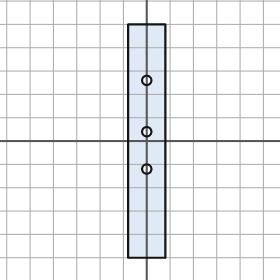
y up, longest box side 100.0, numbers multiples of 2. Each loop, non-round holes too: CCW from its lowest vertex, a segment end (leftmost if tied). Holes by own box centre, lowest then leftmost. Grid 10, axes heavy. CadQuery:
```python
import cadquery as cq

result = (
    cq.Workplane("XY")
    .moveTo(-8.0, -50.0)
    .lineTo(8.0, -50.0)
    .lineTo(8.0, 50.0)
    .lineTo(-8.0, 50.0)
    .close()
    .moveTo(0.0, -12.0)
    .circle(2.0)
    .moveTo(0.0, 4.0)
    .circle(2.0)
    .moveTo(0.0, 26.0)
    .circle(2.0)
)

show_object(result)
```